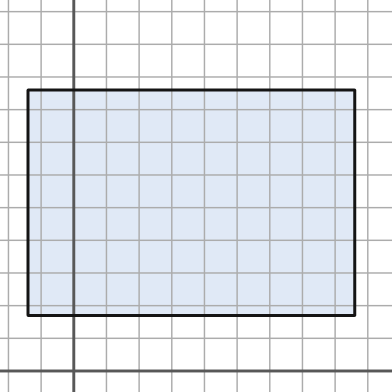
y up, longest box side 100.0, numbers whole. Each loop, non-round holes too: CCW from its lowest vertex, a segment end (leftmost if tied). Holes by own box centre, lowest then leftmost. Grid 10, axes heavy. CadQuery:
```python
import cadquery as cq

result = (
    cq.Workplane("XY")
    .moveTo(-14.0, 17.0)
    .lineTo(86.0, 17.0)
    .lineTo(86.0, 86.0)
    .lineTo(-14.0, 86.0)
    .close()
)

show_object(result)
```